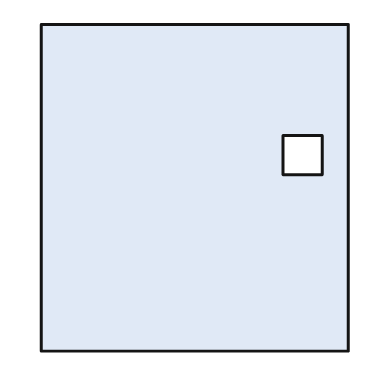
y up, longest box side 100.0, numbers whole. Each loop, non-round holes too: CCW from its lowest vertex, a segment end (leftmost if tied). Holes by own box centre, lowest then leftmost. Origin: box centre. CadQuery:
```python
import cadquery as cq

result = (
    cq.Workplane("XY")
    .moveTo(-47.0, -50.0)
    .lineTo(47.0, -50.0)
    .lineTo(47.0, 50.0)
    .lineTo(-47.0, 50.0)
    .close()
    .moveTo(27.0, 4.0)
    .lineTo(39.0, 4.0)
    .lineTo(39.0, 16.0)
    .lineTo(27.0, 16.0)
    .close()
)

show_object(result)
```